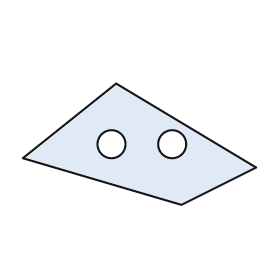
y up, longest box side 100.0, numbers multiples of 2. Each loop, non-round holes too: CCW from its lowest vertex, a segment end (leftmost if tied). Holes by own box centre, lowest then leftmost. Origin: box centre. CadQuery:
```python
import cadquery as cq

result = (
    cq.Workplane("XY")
    .moveTo(18.0, -26.0)
    .lineTo(50.0, -10.0)
    .lineTo(-10.0, 26.0)
    .lineTo(-50.0, -6.0)
    .close()
    .moveTo(-12.0, 0.0)
    .circle(6.0)
    .moveTo(14.0, 0.0)
    .circle(6.0)
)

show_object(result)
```